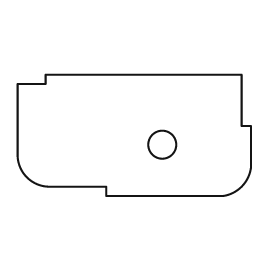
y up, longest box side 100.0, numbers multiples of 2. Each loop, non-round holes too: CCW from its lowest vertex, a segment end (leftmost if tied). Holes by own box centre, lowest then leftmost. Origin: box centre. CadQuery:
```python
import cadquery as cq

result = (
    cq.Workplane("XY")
    .moveTo(-12.0, -26.0)
    .lineTo(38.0, -26.0)
    .threePointArc((46.0, -22.0), (50.0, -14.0))
    .lineTo(50.0, 4.0)
    .lineTo(46.0, 4.0)
    .lineTo(46.0, 26.0)
    .lineTo(-38.0, 26.0)
    .lineTo(-38.0, 22.0)
    .lineTo(-50.0, 22.0)
    .lineTo(-50.0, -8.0)
    .threePointArc((-46.0, -18.0), (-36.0, -22.0))
    .lineTo(-12.0, -22.0)
    .close()
    .moveTo(12.0, -4.0)
    .circle(6.0)
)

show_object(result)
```